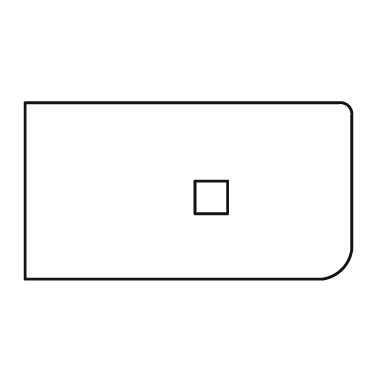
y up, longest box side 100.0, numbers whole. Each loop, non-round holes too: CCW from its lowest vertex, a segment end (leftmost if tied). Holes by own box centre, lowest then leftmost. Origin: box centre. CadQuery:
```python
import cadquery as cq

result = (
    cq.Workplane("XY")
    .moveTo(-50.0, -27.0)
    .lineTo(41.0, -27.0)
    .threePointArc((47.0, -24.0), (50.0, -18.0))
    .lineTo(50.0, 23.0)
    .threePointArc((49.0, 26.0), (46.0, 27.0))
    .lineTo(-50.0, 27.0)
    .close()
    .moveTo(2.0, -7.0)
    .lineTo(12.0, -7.0)
    .lineTo(12.0, 3.0)
    .lineTo(2.0, 3.0)
    .close()
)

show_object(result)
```